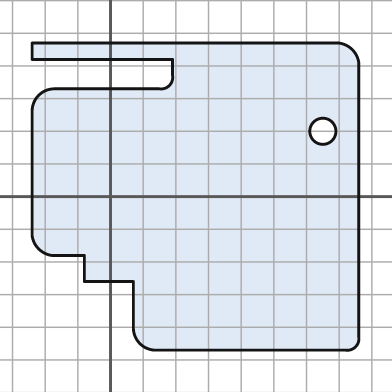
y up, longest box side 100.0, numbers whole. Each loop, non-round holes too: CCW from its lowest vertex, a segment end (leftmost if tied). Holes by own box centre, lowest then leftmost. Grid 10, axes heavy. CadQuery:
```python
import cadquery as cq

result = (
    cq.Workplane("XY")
    .moveTo(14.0, -47.0)
    .lineTo(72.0, -47.0)
    .threePointArc((75.0, -46.0), (76.0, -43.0))
    .lineTo(76.0, 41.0)
    .threePointArc((74.0, 45.0), (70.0, 47.0))
    .lineTo(-24.0, 47.0)
    .lineTo(-24.0, 42.0)
    .lineTo(19.0, 42.0)
    .lineTo(19.0, 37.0)
    .threePointArc((18.0, 34.0), (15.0, 33.0))
    .lineTo(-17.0, 33.0)
    .threePointArc((-22.0, 31.0), (-24.0, 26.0))
    .lineTo(-24.0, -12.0)
    .threePointArc((-22.0, -16.0), (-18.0, -18.0))
    .lineTo(-8.0, -18.0)
    .lineTo(-8.0, -26.0)
    .lineTo(7.0, -26.0)
    .lineTo(7.0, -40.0)
    .threePointArc((9.0, -45.0), (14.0, -47.0))
    .close()
    .moveTo(65.0, 20.0)
    .circle(4.0)
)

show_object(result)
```